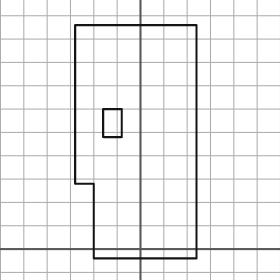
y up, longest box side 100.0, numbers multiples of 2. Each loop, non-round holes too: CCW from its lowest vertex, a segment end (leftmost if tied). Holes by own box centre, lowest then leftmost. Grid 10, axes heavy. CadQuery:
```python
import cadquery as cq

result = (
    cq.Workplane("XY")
    .moveTo(-20.0, -4.0)
    .lineTo(24.0, -4.0)
    .lineTo(24.0, 96.0)
    .lineTo(-28.0, 96.0)
    .lineTo(-28.0, 28.0)
    .lineTo(-20.0, 28.0)
    .close()
    .moveTo(-16.0, 48.0)
    .lineTo(-8.0, 48.0)
    .lineTo(-8.0, 60.0)
    .lineTo(-16.0, 60.0)
    .close()
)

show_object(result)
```